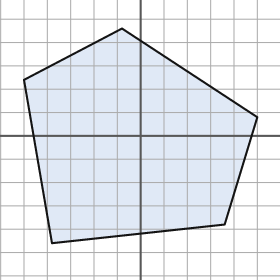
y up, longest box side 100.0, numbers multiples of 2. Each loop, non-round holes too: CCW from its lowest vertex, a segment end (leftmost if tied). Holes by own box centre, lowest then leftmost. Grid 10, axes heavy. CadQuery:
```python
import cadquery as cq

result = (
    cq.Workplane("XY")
    .moveTo(-38.0, -46.0)
    .lineTo(36.0, -38.0)
    .lineTo(50.0, 8.0)
    .lineTo(-8.0, 46.0)
    .lineTo(-50.0, 24.0)
    .close()
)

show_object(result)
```